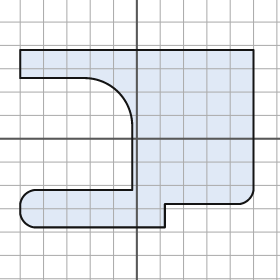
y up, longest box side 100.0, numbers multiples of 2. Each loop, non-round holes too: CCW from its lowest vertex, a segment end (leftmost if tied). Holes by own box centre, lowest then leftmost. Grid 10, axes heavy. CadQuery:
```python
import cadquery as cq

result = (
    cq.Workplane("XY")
    .moveTo(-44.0, -38.0)
    .lineTo(12.0, -38.0)
    .lineTo(12.0, -28.0)
    .lineTo(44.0, -28.0)
    .threePointArc((48.0, -26.0), (50.0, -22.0))
    .lineTo(50.0, 38.0)
    .lineTo(-50.0, 38.0)
    .lineTo(-50.0, 26.0)
    .lineTo(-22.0, 26.0)
    .threePointArc((-8.0, 20.0), (-2.0, 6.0))
    .lineTo(-2.0, -22.0)
    .lineTo(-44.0, -22.0)
    .threePointArc((-48.0, -24.0), (-50.0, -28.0))
    .lineTo(-50.0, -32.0)
    .threePointArc((-48.0, -36.0), (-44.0, -38.0))
    .close()
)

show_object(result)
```